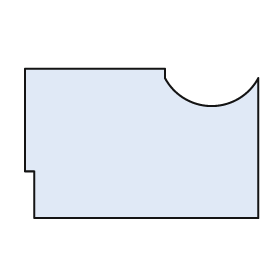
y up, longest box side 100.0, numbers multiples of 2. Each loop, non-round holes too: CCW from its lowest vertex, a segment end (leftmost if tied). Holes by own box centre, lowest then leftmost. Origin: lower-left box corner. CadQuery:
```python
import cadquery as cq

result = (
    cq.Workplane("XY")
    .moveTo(4.0, 0.0)
    .lineTo(100.0, 0.0)
    .lineTo(100.0, 60.0)
    .threePointArc((80.0, 48.0), (60.0, 60.0))
    .lineTo(60.0, 64.0)
    .lineTo(0.0, 64.0)
    .lineTo(0.0, 20.0)
    .lineTo(4.0, 20.0)
    .close()
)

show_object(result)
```